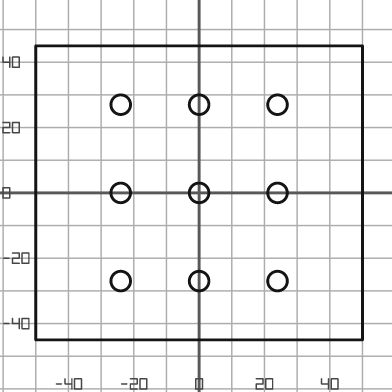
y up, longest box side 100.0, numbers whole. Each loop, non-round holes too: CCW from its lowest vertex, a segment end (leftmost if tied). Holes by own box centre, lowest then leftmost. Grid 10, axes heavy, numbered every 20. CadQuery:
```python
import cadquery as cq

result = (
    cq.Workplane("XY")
    .moveTo(-50.0, -45.0)
    .lineTo(50.0, -45.0)
    .lineTo(50.0, 45.0)
    .lineTo(-50.0, 45.0)
    .close()
    .moveTo(-24.0, -27.0)
    .circle(3.0)
    .moveTo(0.0, -27.0)
    .circle(3.0)
    .moveTo(24.0, -27.0)
    .circle(3.0)
    .moveTo(-24.0, 0.0)
    .circle(3.0)
    .moveTo(0.0, 0.0)
    .circle(3.0)
    .moveTo(24.0, 0.0)
    .circle(3.0)
    .moveTo(-24.0, 27.0)
    .circle(3.0)
    .moveTo(0.0, 27.0)
    .circle(3.0)
    .moveTo(24.0, 27.0)
    .circle(3.0)
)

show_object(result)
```